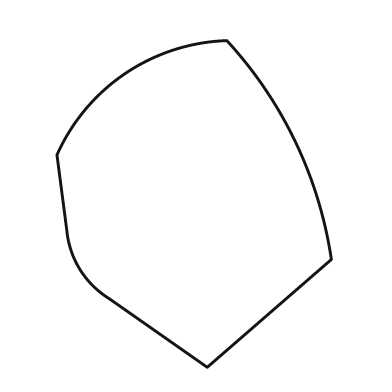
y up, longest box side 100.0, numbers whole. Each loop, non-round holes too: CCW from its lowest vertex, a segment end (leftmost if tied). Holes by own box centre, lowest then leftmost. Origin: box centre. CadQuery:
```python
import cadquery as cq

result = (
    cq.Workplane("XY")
    .moveTo(4.0, -50.0)
    .lineTo(42.0, -17.0)
    .threePointArc((31.0, 19.0), (10.0, 50.0))
    .threePointArc((-21.0, 40.0), (-42.0, 15.0))
    .lineTo(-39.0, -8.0)
    .threePointArc((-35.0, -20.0), (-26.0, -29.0))
    .close()
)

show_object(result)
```